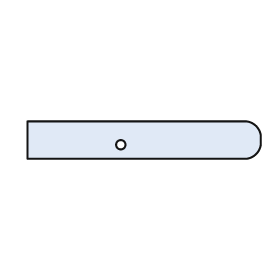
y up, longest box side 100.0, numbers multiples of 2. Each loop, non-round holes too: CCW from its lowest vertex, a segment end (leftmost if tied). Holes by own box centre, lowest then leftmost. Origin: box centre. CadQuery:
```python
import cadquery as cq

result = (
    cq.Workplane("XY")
    .moveTo(-50.0, -8.0)
    .lineTo(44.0, -8.0)
    .threePointArc((48.0, -6.0), (50.0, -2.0))
    .lineTo(50.0, 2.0)
    .threePointArc((48.0, 6.0), (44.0, 8.0))
    .lineTo(-50.0, 8.0)
    .close()
    .moveTo(-10.0, -2.0)
    .circle(2.0)
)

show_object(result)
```